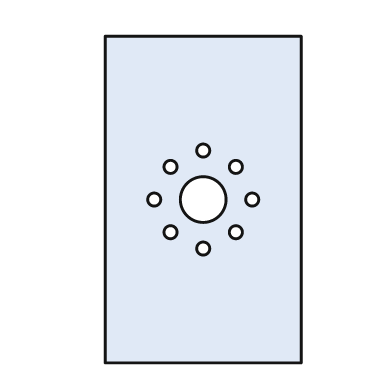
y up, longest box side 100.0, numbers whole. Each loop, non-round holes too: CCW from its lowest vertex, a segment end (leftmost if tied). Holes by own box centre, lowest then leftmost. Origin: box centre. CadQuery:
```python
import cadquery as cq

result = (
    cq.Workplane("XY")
    .moveTo(-30.0, -50.0)
    .lineTo(30.0, -50.0)
    .lineTo(30.0, 50.0)
    .lineTo(-30.0, 50.0)
    .close()
    .moveTo(0.0, -15.0)
    .circle(2.0)
    .moveTo(-10.0, -10.0)
    .circle(2.0)
    .moveTo(10.0, -10.0)
    .circle(2.0)
    .moveTo(-15.0, 0.0)
    .circle(2.0)
    .moveTo(0.0, 0.0)
    .circle(7.0)
    .moveTo(15.0, 0.0)
    .circle(2.0)
    .moveTo(-10.0, 10.0)
    .circle(2.0)
    .moveTo(10.0, 10.0)
    .circle(2.0)
    .moveTo(0.0, 15.0)
    .circle(2.0)
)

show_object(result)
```